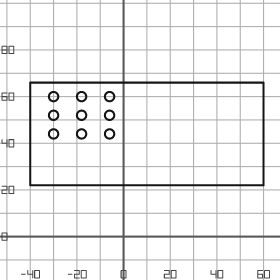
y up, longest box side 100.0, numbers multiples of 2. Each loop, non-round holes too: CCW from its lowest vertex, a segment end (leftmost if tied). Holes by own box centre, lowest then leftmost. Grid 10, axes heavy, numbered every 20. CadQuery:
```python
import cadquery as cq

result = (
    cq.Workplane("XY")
    .moveTo(-40.0, 22.0)
    .lineTo(60.0, 22.0)
    .lineTo(60.0, 66.0)
    .lineTo(-40.0, 66.0)
    .close()
    .moveTo(-30.0, 44.0)
    .circle(2.0)
    .moveTo(-18.0, 44.0)
    .circle(2.0)
    .moveTo(-6.0, 44.0)
    .circle(2.0)
    .moveTo(-30.0, 52.0)
    .circle(2.0)
    .moveTo(-18.0, 52.0)
    .circle(2.0)
    .moveTo(-6.0, 52.0)
    .circle(2.0)
    .moveTo(-30.0, 60.0)
    .circle(2.0)
    .moveTo(-18.0, 60.0)
    .circle(2.0)
    .moveTo(-6.0, 60.0)
    .circle(2.0)
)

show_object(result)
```